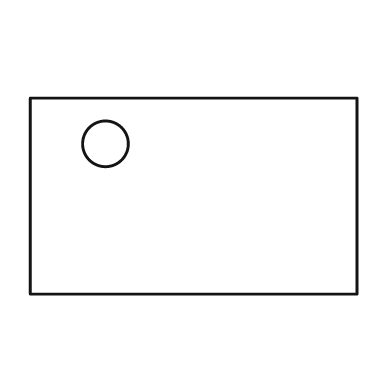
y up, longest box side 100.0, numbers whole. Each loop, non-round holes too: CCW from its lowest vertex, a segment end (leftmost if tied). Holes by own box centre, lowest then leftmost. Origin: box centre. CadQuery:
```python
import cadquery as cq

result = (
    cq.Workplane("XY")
    .moveTo(-50.0, -30.0)
    .lineTo(50.0, -30.0)
    .lineTo(50.0, 30.0)
    .lineTo(-50.0, 30.0)
    .close()
    .moveTo(-27.0, 16.0)
    .circle(7.0)
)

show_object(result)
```